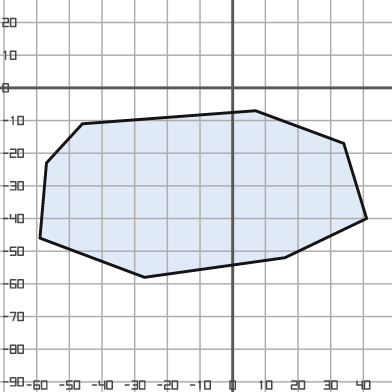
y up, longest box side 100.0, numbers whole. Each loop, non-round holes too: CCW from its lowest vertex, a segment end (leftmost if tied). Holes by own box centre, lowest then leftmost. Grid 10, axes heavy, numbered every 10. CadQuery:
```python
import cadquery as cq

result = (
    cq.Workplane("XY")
    .moveTo(-27.0, -58.0)
    .lineTo(16.0, -52.0)
    .lineTo(41.0, -40.0)
    .lineTo(34.0, -17.0)
    .lineTo(7.0, -7.0)
    .lineTo(-46.0, -11.0)
    .lineTo(-57.0, -23.0)
    .lineTo(-59.0, -46.0)
    .close()
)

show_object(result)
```